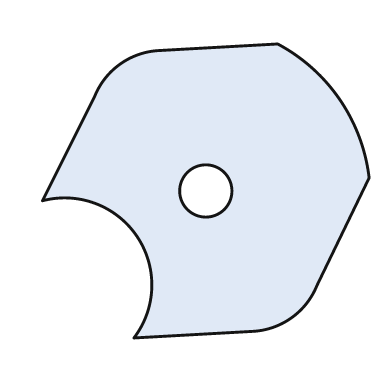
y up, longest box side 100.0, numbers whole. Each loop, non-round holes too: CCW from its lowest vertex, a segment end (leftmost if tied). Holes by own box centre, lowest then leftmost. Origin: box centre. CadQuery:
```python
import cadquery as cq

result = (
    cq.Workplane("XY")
    .moveTo(-22.0, -45.0)
    .lineTo(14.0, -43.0)
    .threePointArc((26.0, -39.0), (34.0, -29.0))
    .lineTo(50.0, 4.0)
    .threePointArc((41.0, 28.0), (22.0, 45.0))
    .lineTo(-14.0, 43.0)
    .threePointArc((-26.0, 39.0), (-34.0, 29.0))
    .lineTo(-50.0, -3.0)
    .threePointArc((-21.0, -14.0), (-22.0, -45.0))
    .close()
    .moveTo(0.0, 0.0)
    .circle(8.0)
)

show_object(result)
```